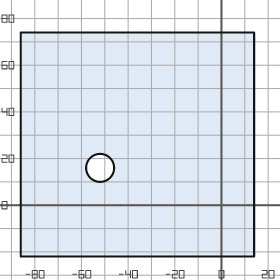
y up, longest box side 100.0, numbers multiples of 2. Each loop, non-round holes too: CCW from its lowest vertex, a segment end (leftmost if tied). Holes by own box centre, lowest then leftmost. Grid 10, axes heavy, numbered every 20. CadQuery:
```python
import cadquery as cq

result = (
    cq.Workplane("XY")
    .moveTo(-86.0, -22.0)
    .lineTo(14.0, -22.0)
    .lineTo(14.0, 74.0)
    .lineTo(-86.0, 74.0)
    .close()
    .moveTo(-52.0, 16.0)
    .circle(6.0)
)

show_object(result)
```